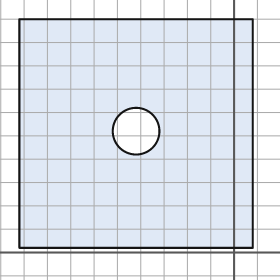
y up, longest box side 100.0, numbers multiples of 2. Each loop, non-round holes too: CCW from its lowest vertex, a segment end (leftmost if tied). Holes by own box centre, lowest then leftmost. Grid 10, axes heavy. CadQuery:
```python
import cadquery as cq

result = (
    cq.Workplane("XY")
    .moveTo(-92.0, 2.0)
    .lineTo(8.0, 2.0)
    .lineTo(8.0, 100.0)
    .lineTo(-92.0, 100.0)
    .close()
    .moveTo(-42.0, 52.0)
    .circle(10.0)
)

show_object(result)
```